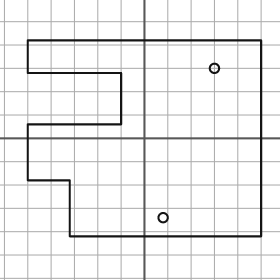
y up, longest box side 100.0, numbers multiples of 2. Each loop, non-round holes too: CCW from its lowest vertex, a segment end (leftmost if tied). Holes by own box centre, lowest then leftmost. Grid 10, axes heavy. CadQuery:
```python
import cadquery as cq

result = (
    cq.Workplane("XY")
    .moveTo(-32.0, -42.0)
    .lineTo(50.0, -42.0)
    .lineTo(50.0, 42.0)
    .lineTo(-50.0, 42.0)
    .lineTo(-50.0, 28.0)
    .lineTo(-10.0, 28.0)
    .lineTo(-10.0, 6.0)
    .lineTo(-50.0, 6.0)
    .lineTo(-50.0, -18.0)
    .lineTo(-32.0, -18.0)
    .close()
    .moveTo(8.0, -34.0)
    .circle(2.0)
    .moveTo(30.0, 30.0)
    .circle(2.0)
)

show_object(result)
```